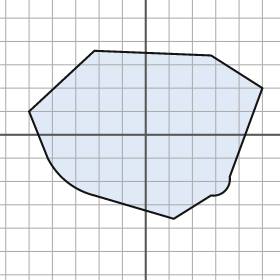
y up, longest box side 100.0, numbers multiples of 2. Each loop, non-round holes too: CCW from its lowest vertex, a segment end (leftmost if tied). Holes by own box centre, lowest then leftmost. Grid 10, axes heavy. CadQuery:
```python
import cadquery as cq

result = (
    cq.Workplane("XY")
    .moveTo(12.0, -36.0)
    .lineTo(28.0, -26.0)
    .threePointArc((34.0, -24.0), (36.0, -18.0))
    .lineTo(50.0, 20.0)
    .lineTo(28.0, 34.0)
    .lineTo(-22.0, 36.0)
    .lineTo(-50.0, 10.0)
    .lineTo(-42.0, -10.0)
    .threePointArc((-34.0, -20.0), (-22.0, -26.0))
    .close()
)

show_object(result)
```